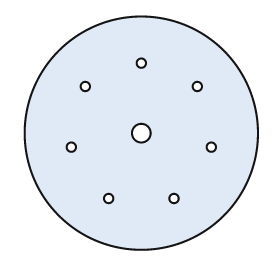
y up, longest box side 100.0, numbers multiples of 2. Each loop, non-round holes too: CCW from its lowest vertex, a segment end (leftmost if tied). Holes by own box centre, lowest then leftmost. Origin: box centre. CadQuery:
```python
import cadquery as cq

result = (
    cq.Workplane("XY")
    .moveTo(0.0, 0.0)
    .circle(50.0)
    .moveTo(-14.0, -28.0)
    .circle(2.0)
    .moveTo(14.0, -28.0)
    .circle(2.0)
    .moveTo(-30.0, -6.0)
    .circle(2.0)
    .moveTo(30.0, -6.0)
    .circle(2.0)
    .moveTo(0.0, 0.0)
    .circle(4.0)
    .moveTo(-24.0, 20.0)
    .circle(2.0)
    .moveTo(24.0, 20.0)
    .circle(2.0)
    .moveTo(0.0, 30.0)
    .circle(2.0)
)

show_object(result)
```